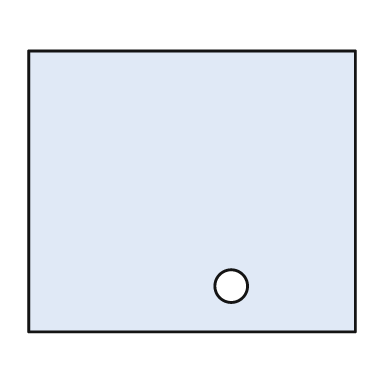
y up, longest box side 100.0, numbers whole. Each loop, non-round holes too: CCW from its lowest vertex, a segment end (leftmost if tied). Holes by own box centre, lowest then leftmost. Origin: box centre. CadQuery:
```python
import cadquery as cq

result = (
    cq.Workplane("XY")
    .moveTo(-50.0, -43.0)
    .lineTo(50.0, -43.0)
    .lineTo(50.0, 43.0)
    .lineTo(-50.0, 43.0)
    .close()
    .moveTo(12.0, -29.0)
    .circle(5.0)
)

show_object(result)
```